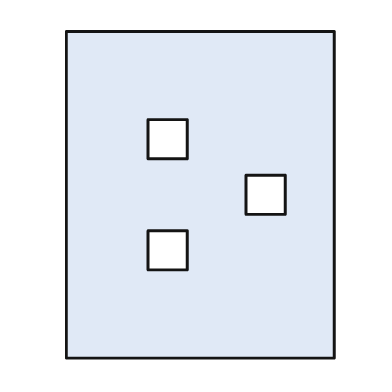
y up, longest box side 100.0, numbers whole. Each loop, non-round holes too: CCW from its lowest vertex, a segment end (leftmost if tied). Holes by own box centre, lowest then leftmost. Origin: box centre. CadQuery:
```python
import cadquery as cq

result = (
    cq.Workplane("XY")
    .moveTo(-41.0, -50.0)
    .lineTo(41.0, -50.0)
    .lineTo(41.0, 50.0)
    .lineTo(-41.0, 50.0)
    .close()
    .moveTo(-16.0, -23.0)
    .lineTo(-4.0, -23.0)
    .lineTo(-4.0, -11.0)
    .lineTo(-16.0, -11.0)
    .close()
    .moveTo(14.0, -6.0)
    .lineTo(26.0, -6.0)
    .lineTo(26.0, 6.0)
    .lineTo(14.0, 6.0)
    .close()
    .moveTo(-16.0, 11.0)
    .lineTo(-4.0, 11.0)
    .lineTo(-4.0, 23.0)
    .lineTo(-16.0, 23.0)
    .close()
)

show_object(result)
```